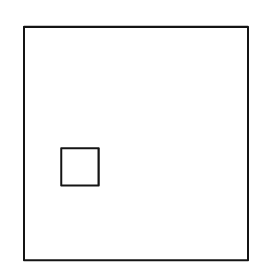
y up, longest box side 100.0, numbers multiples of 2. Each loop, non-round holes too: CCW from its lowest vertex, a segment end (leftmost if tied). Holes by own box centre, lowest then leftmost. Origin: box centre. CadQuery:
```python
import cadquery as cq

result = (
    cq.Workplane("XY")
    .moveTo(-48.0, -50.0)
    .lineTo(48.0, -50.0)
    .lineTo(48.0, 50.0)
    .lineTo(-48.0, 50.0)
    .close()
    .moveTo(-32.0, -18.0)
    .lineTo(-16.0, -18.0)
    .lineTo(-16.0, -2.0)
    .lineTo(-32.0, -2.0)
    .close()
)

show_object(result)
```